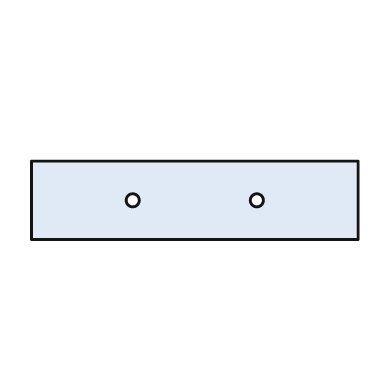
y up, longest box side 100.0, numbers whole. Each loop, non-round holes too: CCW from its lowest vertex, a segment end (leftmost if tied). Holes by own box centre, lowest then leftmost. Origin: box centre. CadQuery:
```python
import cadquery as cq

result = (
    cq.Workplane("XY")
    .moveTo(-50.0, -12.0)
    .lineTo(50.0, -12.0)
    .lineTo(50.0, 12.0)
    .lineTo(-50.0, 12.0)
    .close()
    .moveTo(-19.0, 0.0)
    .circle(2.0)
    .moveTo(19.0, 0.0)
    .circle(2.0)
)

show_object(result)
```